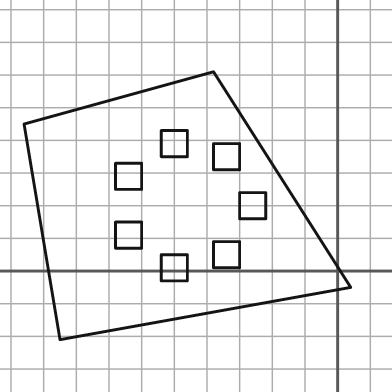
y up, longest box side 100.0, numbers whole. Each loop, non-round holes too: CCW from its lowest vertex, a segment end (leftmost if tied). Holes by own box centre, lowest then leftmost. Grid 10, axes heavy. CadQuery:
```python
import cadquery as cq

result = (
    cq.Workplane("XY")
    .moveTo(-85.0, -21.0)
    .lineTo(4.0, -5.0)
    .lineTo(-38.0, 61.0)
    .lineTo(-96.0, 45.0)
    .close()
    .moveTo(-54.0, -3.0)
    .lineTo(-46.0, -3.0)
    .lineTo(-46.0, 5.0)
    .lineTo(-54.0, 5.0)
    .close()
    .moveTo(-38.0, 1.0)
    .lineTo(-30.0, 1.0)
    .lineTo(-30.0, 9.0)
    .lineTo(-38.0, 9.0)
    .close()
    .moveTo(-68.0, 7.0)
    .lineTo(-60.0, 7.0)
    .lineTo(-60.0, 15.0)
    .lineTo(-68.0, 15.0)
    .close()
    .moveTo(-30.0, 16.0)
    .lineTo(-22.0, 16.0)
    .lineTo(-22.0, 24.0)
    .lineTo(-30.0, 24.0)
    .close()
    .moveTo(-68.0, 25.0)
    .lineTo(-60.0, 25.0)
    .lineTo(-60.0, 33.0)
    .lineTo(-68.0, 33.0)
    .close()
    .moveTo(-38.0, 31.0)
    .lineTo(-30.0, 31.0)
    .lineTo(-30.0, 39.0)
    .lineTo(-38.0, 39.0)
    .close()
    .moveTo(-54.0, 35.0)
    .lineTo(-46.0, 35.0)
    .lineTo(-46.0, 43.0)
    .lineTo(-54.0, 43.0)
    .close()
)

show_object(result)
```